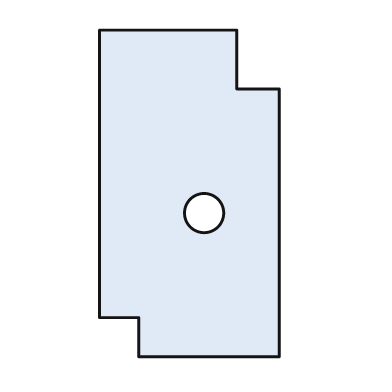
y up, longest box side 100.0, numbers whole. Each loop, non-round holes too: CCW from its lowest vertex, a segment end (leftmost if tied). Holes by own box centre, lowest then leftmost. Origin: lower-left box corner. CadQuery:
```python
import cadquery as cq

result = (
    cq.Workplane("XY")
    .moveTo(12.0, 0.0)
    .lineTo(55.0, 0.0)
    .lineTo(55.0, 82.0)
    .lineTo(42.0, 82.0)
    .lineTo(42.0, 100.0)
    .lineTo(0.0, 100.0)
    .lineTo(0.0, 12.0)
    .lineTo(12.0, 12.0)
    .close()
    .moveTo(32.0, 44.0)
    .circle(6.0)
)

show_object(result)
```